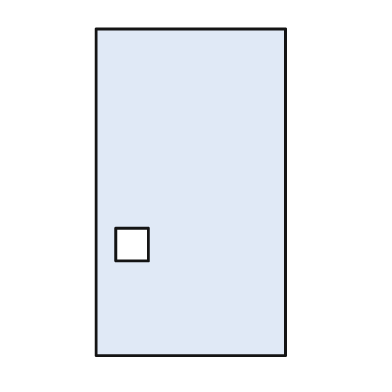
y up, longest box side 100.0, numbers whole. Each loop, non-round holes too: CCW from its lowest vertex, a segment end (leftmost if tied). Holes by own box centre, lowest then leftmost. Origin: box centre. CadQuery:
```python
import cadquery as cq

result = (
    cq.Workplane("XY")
    .moveTo(-29.0, -50.0)
    .lineTo(29.0, -50.0)
    .lineTo(29.0, 50.0)
    .lineTo(-29.0, 50.0)
    .close()
    .moveTo(-23.0, -21.0)
    .lineTo(-13.0, -21.0)
    .lineTo(-13.0, -11.0)
    .lineTo(-23.0, -11.0)
    .close()
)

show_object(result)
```